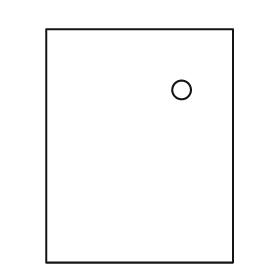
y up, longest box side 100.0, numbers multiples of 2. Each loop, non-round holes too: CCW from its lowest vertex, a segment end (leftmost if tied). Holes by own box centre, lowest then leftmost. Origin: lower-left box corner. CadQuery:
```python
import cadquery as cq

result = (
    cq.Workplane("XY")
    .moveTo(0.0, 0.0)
    .lineTo(80.0, 0.0)
    .lineTo(80.0, 100.0)
    .lineTo(0.0, 100.0)
    .close()
    .moveTo(58.0, 74.0)
    .circle(4.0)
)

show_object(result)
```